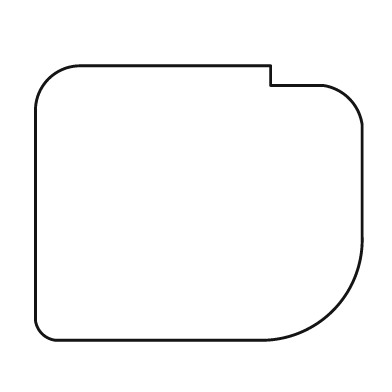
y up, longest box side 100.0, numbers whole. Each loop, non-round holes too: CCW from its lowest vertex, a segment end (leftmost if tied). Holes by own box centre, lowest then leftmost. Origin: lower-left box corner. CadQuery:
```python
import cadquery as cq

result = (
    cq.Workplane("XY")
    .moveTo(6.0, 0.0)
    .lineTo(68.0, 0.0)
    .threePointArc((91.0, 9.0), (100.0, 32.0))
    .lineTo(100.0, 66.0)
    .threePointArc((96.0, 74.0), (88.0, 78.0))
    .lineTo(72.0, 78.0)
    .lineTo(72.0, 84.0)
    .lineTo(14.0, 84.0)
    .threePointArc((4.0, 80.0), (0.0, 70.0))
    .lineTo(0.0, 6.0)
    .threePointArc((2.0, 2.0), (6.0, 0.0))
    .close()
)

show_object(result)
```